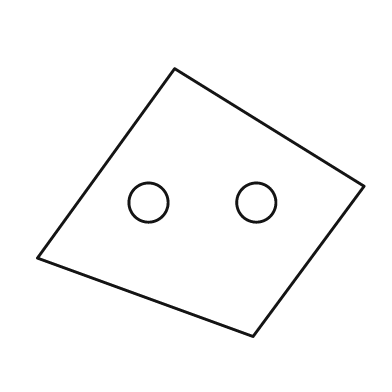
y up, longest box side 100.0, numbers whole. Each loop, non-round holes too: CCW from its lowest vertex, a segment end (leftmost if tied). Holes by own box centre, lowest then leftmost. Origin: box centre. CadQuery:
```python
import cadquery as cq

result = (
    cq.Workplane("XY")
    .moveTo(16.0, -41.0)
    .lineTo(50.0, 5.0)
    .lineTo(-8.0, 41.0)
    .lineTo(-50.0, -17.0)
    .close()
    .moveTo(-16.0, 0.0)
    .circle(6.0)
    .moveTo(17.0, 0.0)
    .circle(6.0)
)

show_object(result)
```